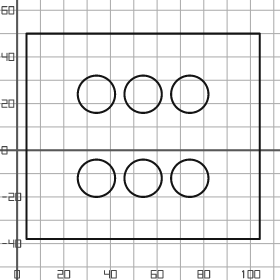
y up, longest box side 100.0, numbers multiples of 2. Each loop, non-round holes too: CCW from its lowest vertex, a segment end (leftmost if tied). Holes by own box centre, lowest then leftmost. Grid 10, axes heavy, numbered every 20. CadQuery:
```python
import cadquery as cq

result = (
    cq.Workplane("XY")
    .moveTo(4.0, -38.0)
    .lineTo(104.0, -38.0)
    .lineTo(104.0, 50.0)
    .lineTo(4.0, 50.0)
    .close()
    .moveTo(34.0, -12.0)
    .circle(8.0)
    .moveTo(54.0, -12.0)
    .circle(8.0)
    .moveTo(74.0, -12.0)
    .circle(8.0)
    .moveTo(34.0, 24.0)
    .circle(8.0)
    .moveTo(54.0, 24.0)
    .circle(8.0)
    .moveTo(74.0, 24.0)
    .circle(8.0)
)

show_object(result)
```